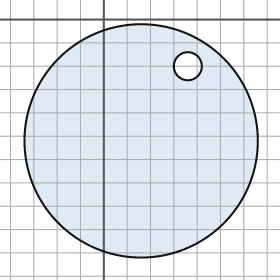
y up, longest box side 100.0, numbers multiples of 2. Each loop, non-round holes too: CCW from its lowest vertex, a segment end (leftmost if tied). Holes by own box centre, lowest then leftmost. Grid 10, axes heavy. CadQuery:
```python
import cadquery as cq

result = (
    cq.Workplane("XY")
    .moveTo(16.0, -52.0)
    .circle(50.0)
    .moveTo(36.0, -20.0)
    .circle(6.0)
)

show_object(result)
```